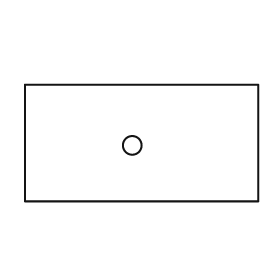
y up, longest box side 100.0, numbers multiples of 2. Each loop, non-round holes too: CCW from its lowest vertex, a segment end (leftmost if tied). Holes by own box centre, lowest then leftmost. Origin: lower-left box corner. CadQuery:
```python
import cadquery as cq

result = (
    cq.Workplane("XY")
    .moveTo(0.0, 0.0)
    .lineTo(100.0, 0.0)
    .lineTo(100.0, 50.0)
    .lineTo(0.0, 50.0)
    .close()
    .moveTo(46.0, 24.0)
    .circle(4.0)
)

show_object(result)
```